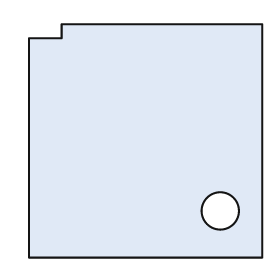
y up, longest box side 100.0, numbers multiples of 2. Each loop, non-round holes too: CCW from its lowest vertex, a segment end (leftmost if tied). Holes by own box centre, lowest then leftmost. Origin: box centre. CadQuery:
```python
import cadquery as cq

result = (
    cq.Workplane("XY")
    .moveTo(-50.0, -50.0)
    .lineTo(50.0, -50.0)
    .lineTo(50.0, 50.0)
    .lineTo(-36.0, 50.0)
    .lineTo(-36.0, 44.0)
    .lineTo(-50.0, 44.0)
    .close()
    .moveTo(32.0, -30.0)
    .circle(8.0)
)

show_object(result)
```